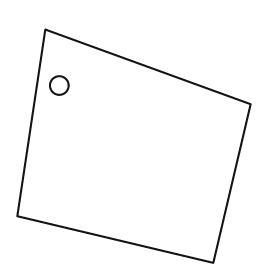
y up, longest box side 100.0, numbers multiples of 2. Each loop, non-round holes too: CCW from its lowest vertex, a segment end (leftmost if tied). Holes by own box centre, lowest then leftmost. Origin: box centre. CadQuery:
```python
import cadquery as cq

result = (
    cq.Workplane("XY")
    .moveTo(34.0, -50.0)
    .lineTo(50.0, 18.0)
    .lineTo(-38.0, 50.0)
    .lineTo(-50.0, -30.0)
    .close()
    .moveTo(-32.0, 26.0)
    .circle(4.0)
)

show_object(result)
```